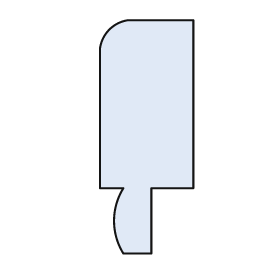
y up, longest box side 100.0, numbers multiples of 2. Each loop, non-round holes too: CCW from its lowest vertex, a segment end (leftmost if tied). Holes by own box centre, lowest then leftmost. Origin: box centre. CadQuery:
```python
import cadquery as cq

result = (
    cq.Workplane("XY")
    .moveTo(-10.0, -50.0)
    .lineTo(2.0, -50.0)
    .lineTo(2.0, -22.0)
    .lineTo(20.0, -22.0)
    .lineTo(20.0, 50.0)
    .lineTo(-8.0, 50.0)
    .threePointArc((-16.0, 46.0), (-20.0, 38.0))
    .lineTo(-20.0, -22.0)
    .lineTo(-10.0, -22.0)
    .threePointArc((-14.0, -36.0), (-10.0, -50.0))
    .close()
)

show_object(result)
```